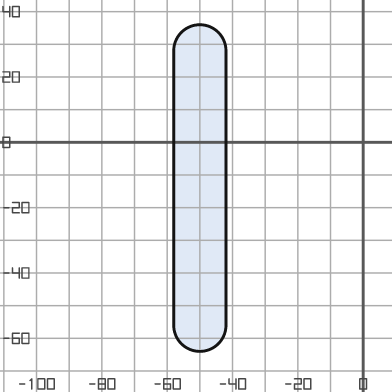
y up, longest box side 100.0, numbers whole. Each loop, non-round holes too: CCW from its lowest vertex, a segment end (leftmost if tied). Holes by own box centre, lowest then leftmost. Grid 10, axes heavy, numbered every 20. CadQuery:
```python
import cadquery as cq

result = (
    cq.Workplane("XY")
    .moveTo(-58.0, -56.0)
    .threePointArc((-50.0, -64.0), (-42.0, -56.0))
    .lineTo(-42.0, 28.0)
    .threePointArc((-50.0, 36.0), (-58.0, 28.0))
    .close()
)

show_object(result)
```